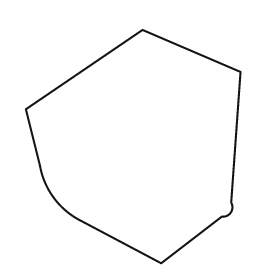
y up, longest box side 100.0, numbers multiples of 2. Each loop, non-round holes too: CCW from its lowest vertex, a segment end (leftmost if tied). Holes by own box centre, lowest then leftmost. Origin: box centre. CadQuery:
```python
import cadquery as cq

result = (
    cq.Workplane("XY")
    .moveTo(12.0, -50.0)
    .lineTo(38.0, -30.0)
    .threePointArc((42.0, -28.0), (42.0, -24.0))
    .lineTo(46.0, 32.0)
    .lineTo(4.0, 50.0)
    .lineTo(-46.0, 16.0)
    .lineTo(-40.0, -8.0)
    .threePointArc((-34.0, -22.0), (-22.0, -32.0))
    .close()
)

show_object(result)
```